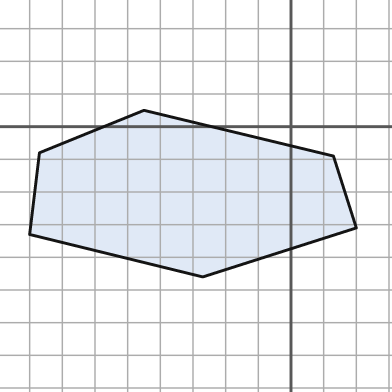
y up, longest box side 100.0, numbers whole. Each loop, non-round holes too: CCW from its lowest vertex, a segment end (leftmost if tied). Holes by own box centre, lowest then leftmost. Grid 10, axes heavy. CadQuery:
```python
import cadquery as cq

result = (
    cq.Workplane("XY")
    .moveTo(-27.0, -46.0)
    .lineTo(20.0, -31.0)
    .lineTo(13.0, -9.0)
    .lineTo(-45.0, 5.0)
    .lineTo(-77.0, -8.0)
    .lineTo(-80.0, -33.0)
    .close()
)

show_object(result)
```